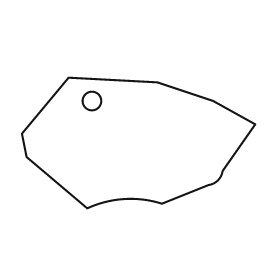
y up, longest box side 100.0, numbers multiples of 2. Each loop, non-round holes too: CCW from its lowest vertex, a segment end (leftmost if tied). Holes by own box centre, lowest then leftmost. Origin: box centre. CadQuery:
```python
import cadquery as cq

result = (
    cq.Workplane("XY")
    .moveTo(-22.0, -28.0)
    .threePointArc((-6.0, -24.0), (10.0, -26.0))
    .lineTo(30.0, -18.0)
    .threePointArc((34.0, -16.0), (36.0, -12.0))
    .lineTo(50.0, 8.0)
    .lineTo(32.0, 18.0)
    .lineTo(8.0, 26.0)
    .lineTo(-30.0, 28.0)
    .lineTo(-50.0, 4.0)
    .lineTo(-48.0, -6.0)
    .close()
    .moveTo(-20.0, 18.0)
    .circle(4.0)
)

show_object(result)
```